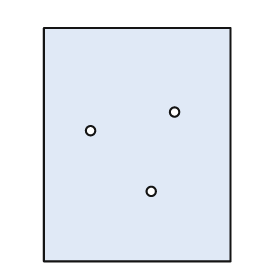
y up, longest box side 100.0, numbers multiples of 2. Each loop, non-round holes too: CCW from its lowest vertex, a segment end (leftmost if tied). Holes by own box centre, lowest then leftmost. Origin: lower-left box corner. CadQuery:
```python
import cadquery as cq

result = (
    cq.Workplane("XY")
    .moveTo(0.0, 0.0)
    .lineTo(80.0, 0.0)
    .lineTo(80.0, 100.0)
    .lineTo(0.0, 100.0)
    .close()
    .moveTo(46.0, 30.0)
    .circle(2.0)
    .moveTo(20.0, 56.0)
    .circle(2.0)
    .moveTo(56.0, 64.0)
    .circle(2.0)
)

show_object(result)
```